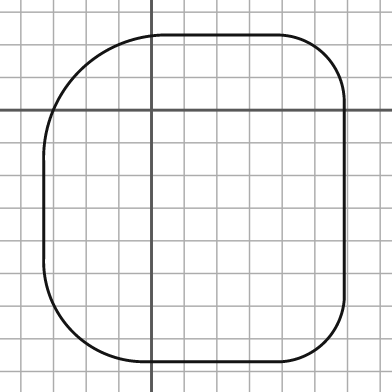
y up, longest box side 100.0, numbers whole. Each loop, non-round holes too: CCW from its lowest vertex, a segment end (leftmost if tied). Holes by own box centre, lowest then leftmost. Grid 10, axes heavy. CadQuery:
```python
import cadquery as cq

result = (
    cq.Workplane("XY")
    .moveTo(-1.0, -77.0)
    .lineTo(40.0, -77.0)
    .threePointArc((53.0, -71.0), (59.0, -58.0))
    .lineTo(59.0, 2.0)
    .threePointArc((53.0, 17.0), (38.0, 23.0))
    .lineTo(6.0, 23.0)
    .threePointArc((-22.0, 12.0), (-33.0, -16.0))
    .lineTo(-33.0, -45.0)
    .threePointArc((-24.0, -68.0), (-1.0, -77.0))
    .close()
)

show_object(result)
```